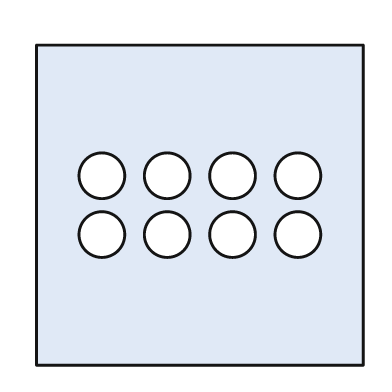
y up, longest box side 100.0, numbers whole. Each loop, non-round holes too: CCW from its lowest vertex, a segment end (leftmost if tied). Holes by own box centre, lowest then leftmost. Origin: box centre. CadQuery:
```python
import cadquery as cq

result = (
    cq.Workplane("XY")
    .moveTo(-50.0, -49.0)
    .lineTo(50.0, -49.0)
    .lineTo(50.0, 49.0)
    .lineTo(-50.0, 49.0)
    .close()
    .moveTo(-30.0, -9.0)
    .circle(7.0)
    .moveTo(-10.0, -9.0)
    .circle(7.0)
    .moveTo(10.0, -9.0)
    .circle(7.0)
    .moveTo(30.0, -9.0)
    .circle(7.0)
    .moveTo(-30.0, 9.0)
    .circle(7.0)
    .moveTo(-10.0, 9.0)
    .circle(7.0)
    .moveTo(10.0, 9.0)
    .circle(7.0)
    .moveTo(30.0, 9.0)
    .circle(7.0)
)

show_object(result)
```